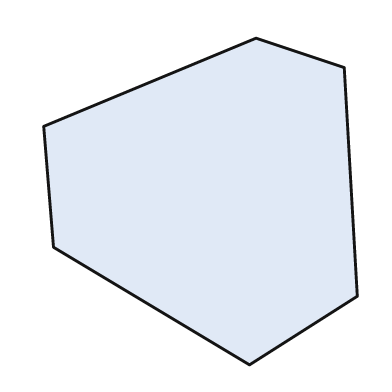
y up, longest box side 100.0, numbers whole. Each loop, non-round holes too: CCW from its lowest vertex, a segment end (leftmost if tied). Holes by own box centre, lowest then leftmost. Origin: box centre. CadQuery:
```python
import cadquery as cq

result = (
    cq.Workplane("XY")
    .moveTo(15.0, -50.0)
    .lineTo(48.0, -29.0)
    .lineTo(44.0, 41.0)
    .lineTo(17.0, 50.0)
    .lineTo(-48.0, 23.0)
    .lineTo(-45.0, -14.0)
    .close()
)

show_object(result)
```